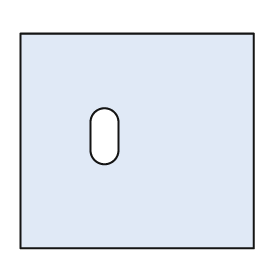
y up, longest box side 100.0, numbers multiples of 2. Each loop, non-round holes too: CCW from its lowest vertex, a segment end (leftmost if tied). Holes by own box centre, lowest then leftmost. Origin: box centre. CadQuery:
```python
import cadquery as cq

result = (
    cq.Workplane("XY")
    .moveTo(-50.0, -46.0)
    .lineTo(50.0, -46.0)
    .lineTo(50.0, 46.0)
    .lineTo(-50.0, 46.0)
    .close()
    .moveTo(-20.0, -4.0)
    .threePointArc((-14.0, -10.0), (-8.0, -4.0))
    .lineTo(-8.0, 8.0)
    .threePointArc((-14.0, 14.0), (-20.0, 8.0))
    .close()
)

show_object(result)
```